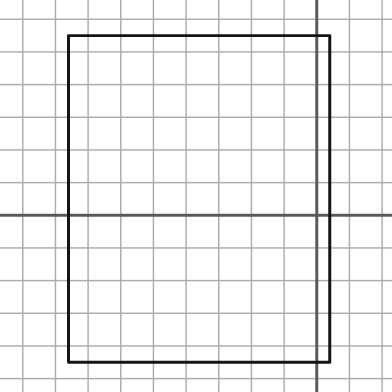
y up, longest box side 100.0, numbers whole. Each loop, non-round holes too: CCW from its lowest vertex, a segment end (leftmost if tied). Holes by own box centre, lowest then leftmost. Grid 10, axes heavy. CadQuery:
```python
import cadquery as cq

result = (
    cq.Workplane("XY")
    .moveTo(-76.0, -45.0)
    .lineTo(4.0, -45.0)
    .lineTo(4.0, 55.0)
    .lineTo(-76.0, 55.0)
    .close()
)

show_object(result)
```